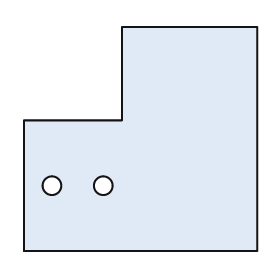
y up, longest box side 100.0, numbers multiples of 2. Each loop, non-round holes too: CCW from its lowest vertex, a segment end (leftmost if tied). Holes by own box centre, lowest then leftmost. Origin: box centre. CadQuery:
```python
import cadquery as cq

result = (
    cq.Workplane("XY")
    .moveTo(-50.0, -48.0)
    .lineTo(50.0, -48.0)
    .lineTo(50.0, 48.0)
    .lineTo(-8.0, 48.0)
    .lineTo(-8.0, 8.0)
    .lineTo(-50.0, 8.0)
    .close()
    .moveTo(-38.0, -20.0)
    .circle(4.0)
    .moveTo(-16.0, -20.0)
    .circle(4.0)
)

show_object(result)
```